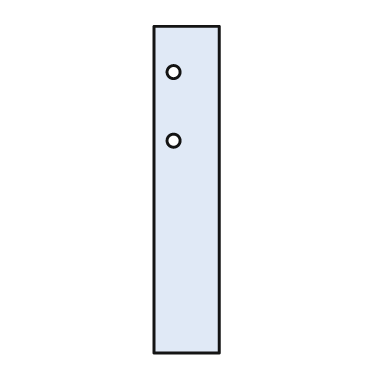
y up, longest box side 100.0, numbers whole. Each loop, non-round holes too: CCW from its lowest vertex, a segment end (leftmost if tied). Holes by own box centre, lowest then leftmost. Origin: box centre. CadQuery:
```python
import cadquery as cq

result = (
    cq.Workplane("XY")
    .moveTo(-10.0, -50.0)
    .lineTo(10.0, -50.0)
    .lineTo(10.0, 50.0)
    .lineTo(-10.0, 50.0)
    .close()
    .moveTo(-4.0, 15.0)
    .circle(2.0)
    .moveTo(-4.0, 36.0)
    .circle(2.0)
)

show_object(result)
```